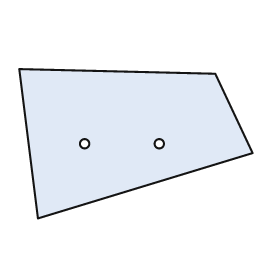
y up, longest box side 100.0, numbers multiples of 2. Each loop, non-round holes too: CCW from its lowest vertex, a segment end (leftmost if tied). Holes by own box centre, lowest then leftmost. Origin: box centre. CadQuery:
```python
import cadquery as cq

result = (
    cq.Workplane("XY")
    .moveTo(-42.0, -32.0)
    .lineTo(50.0, -4.0)
    .lineTo(34.0, 30.0)
    .lineTo(-50.0, 32.0)
    .close()
    .moveTo(-22.0, 0.0)
    .circle(2.0)
    .moveTo(10.0, 0.0)
    .circle(2.0)
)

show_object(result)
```